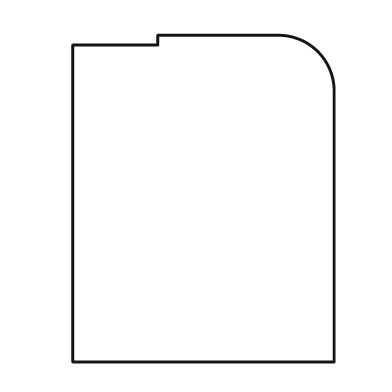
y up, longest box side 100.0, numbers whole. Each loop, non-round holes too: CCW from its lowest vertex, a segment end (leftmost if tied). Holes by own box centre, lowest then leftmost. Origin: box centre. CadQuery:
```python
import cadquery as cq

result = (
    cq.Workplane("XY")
    .moveTo(-40.0, -50.0)
    .lineTo(40.0, -50.0)
    .lineTo(40.0, 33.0)
    .threePointArc((35.0, 45.0), (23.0, 50.0))
    .lineTo(-14.0, 50.0)
    .lineTo(-14.0, 47.0)
    .lineTo(-40.0, 47.0)
    .close()
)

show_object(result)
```